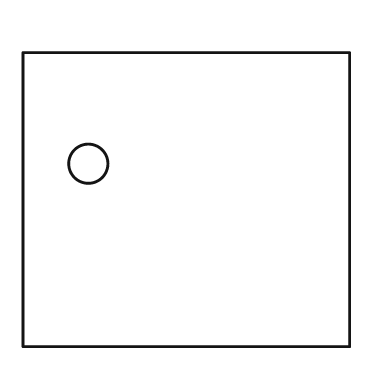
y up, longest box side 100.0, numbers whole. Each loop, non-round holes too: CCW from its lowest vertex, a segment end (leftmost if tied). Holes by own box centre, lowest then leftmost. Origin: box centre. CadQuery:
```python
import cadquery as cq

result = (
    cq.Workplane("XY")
    .moveTo(-50.0, -45.0)
    .lineTo(50.0, -45.0)
    .lineTo(50.0, 45.0)
    .lineTo(-50.0, 45.0)
    .close()
    .moveTo(-30.0, 11.0)
    .circle(6.0)
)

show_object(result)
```